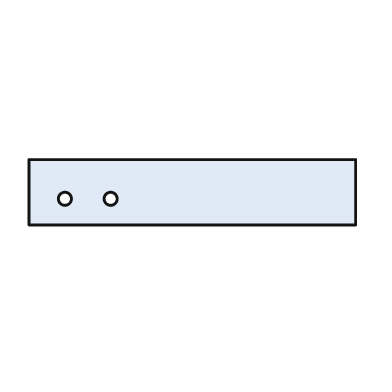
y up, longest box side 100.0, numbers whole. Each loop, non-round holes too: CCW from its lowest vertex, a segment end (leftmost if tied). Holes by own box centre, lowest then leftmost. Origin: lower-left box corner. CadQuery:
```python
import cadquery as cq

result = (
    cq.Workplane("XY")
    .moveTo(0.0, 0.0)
    .lineTo(100.0, 0.0)
    .lineTo(100.0, 20.0)
    .lineTo(0.0, 20.0)
    .close()
    .moveTo(11.0, 8.0)
    .circle(2.0)
    .moveTo(25.0, 8.0)
    .circle(2.0)
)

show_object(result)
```